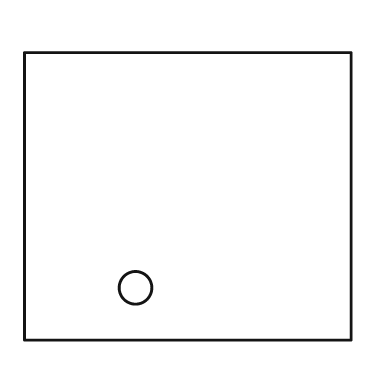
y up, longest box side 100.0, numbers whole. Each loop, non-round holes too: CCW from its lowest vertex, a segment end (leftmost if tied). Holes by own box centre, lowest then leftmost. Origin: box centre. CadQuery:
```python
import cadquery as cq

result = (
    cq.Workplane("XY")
    .moveTo(-50.0, -44.0)
    .lineTo(50.0, -44.0)
    .lineTo(50.0, 44.0)
    .lineTo(-50.0, 44.0)
    .close()
    .moveTo(-16.0, -28.0)
    .circle(5.0)
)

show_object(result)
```